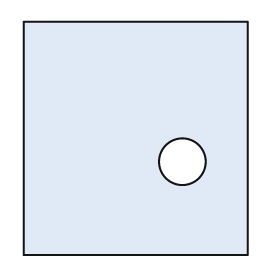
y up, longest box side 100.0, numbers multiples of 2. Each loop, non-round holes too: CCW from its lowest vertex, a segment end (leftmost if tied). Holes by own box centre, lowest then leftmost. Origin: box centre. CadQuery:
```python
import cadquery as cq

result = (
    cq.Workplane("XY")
    .moveTo(-48.0, -50.0)
    .lineTo(48.0, -50.0)
    .lineTo(48.0, 50.0)
    .lineTo(-48.0, 50.0)
    .close()
    .moveTo(20.0, -10.0)
    .circle(10.0)
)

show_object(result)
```